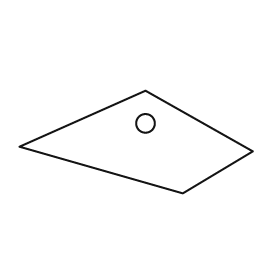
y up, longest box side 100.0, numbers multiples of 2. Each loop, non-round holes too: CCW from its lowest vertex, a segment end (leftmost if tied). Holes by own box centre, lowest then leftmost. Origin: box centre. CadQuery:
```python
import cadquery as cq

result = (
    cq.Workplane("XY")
    .moveTo(20.0, -22.0)
    .lineTo(50.0, -4.0)
    .lineTo(4.0, 22.0)
    .lineTo(-50.0, -2.0)
    .close()
    .moveTo(4.0, 8.0)
    .circle(4.0)
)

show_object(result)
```